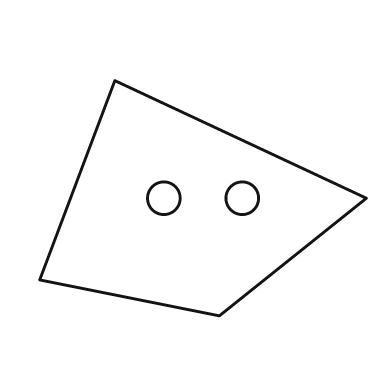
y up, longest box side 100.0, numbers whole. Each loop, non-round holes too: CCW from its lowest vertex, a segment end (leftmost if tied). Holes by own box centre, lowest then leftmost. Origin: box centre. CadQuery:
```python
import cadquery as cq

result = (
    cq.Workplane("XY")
    .moveTo(5.0, -36.0)
    .lineTo(50.0, 0.0)
    .lineTo(-27.0, 36.0)
    .lineTo(-50.0, -25.0)
    .close()
    .moveTo(-12.0, 0.0)
    .circle(5.0)
    .moveTo(12.0, 0.0)
    .circle(5.0)
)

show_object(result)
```